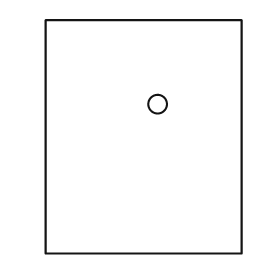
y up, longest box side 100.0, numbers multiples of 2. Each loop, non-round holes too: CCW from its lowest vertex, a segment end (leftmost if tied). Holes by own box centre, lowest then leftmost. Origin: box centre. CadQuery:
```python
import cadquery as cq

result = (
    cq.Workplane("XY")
    .moveTo(-42.0, -50.0)
    .lineTo(42.0, -50.0)
    .lineTo(42.0, 50.0)
    .lineTo(-42.0, 50.0)
    .close()
    .moveTo(6.0, 14.0)
    .circle(4.0)
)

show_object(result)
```